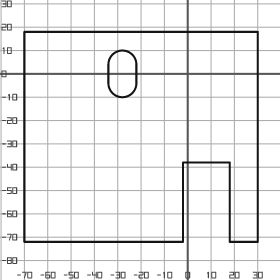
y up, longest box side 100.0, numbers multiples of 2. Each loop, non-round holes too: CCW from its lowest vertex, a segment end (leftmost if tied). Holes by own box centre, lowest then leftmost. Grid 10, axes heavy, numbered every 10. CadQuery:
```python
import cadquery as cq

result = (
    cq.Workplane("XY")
    .moveTo(-70.0, -72.0)
    .lineTo(-2.0, -72.0)
    .lineTo(-2.0, -38.0)
    .lineTo(18.0, -38.0)
    .lineTo(18.0, -72.0)
    .lineTo(30.0, -72.0)
    .lineTo(30.0, 18.0)
    .lineTo(-70.0, 18.0)
    .close()
    .moveTo(-34.0, -4.0)
    .threePointArc((-28.0, -10.0), (-22.0, -4.0))
    .lineTo(-22.0, 4.0)
    .threePointArc((-28.0, 10.0), (-34.0, 4.0))
    .close()
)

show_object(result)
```